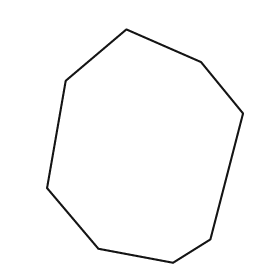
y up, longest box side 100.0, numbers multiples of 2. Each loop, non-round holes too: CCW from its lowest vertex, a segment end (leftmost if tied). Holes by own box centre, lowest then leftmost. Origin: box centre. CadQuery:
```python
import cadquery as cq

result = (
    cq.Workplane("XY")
    .moveTo(12.0, -50.0)
    .lineTo(28.0, -40.0)
    .lineTo(42.0, 14.0)
    .lineTo(24.0, 36.0)
    .lineTo(-8.0, 50.0)
    .lineTo(-34.0, 28.0)
    .lineTo(-42.0, -18.0)
    .lineTo(-20.0, -44.0)
    .close()
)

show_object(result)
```